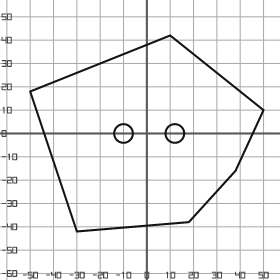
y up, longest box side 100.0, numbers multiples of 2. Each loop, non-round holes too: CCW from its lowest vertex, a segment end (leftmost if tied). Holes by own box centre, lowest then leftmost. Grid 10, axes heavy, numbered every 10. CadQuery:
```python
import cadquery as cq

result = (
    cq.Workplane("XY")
    .moveTo(-30.0, -42.0)
    .lineTo(18.0, -38.0)
    .lineTo(38.0, -16.0)
    .lineTo(50.0, 10.0)
    .lineTo(10.0, 42.0)
    .lineTo(-50.0, 18.0)
    .close()
    .moveTo(-10.0, 0.0)
    .circle(4.0)
    .moveTo(12.0, 0.0)
    .circle(4.0)
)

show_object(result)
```